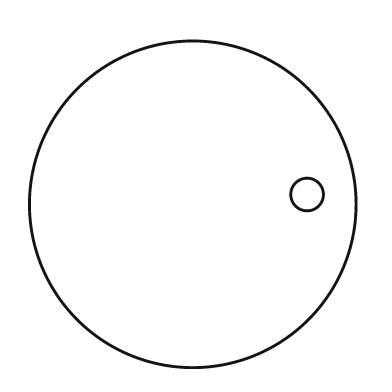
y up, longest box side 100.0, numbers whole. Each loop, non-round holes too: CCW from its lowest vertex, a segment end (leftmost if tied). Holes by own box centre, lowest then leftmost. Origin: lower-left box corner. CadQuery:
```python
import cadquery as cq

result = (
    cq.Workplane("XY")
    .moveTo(50.0, 50.0)
    .circle(50.0)
    .moveTo(85.0, 53.0)
    .circle(5.0)
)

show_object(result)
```